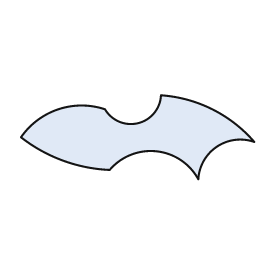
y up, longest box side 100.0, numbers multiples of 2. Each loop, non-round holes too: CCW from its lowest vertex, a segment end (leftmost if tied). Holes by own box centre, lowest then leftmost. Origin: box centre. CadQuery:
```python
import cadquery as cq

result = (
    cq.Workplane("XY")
    .moveTo(26.0, -18.0)
    .threePointArc((34.0, -4.0), (50.0, -2.0))
    .threePointArc((32.0, 12.0), (10.0, 18.0))
    .threePointArc((0.0, 6.0), (-14.0, 12.0))
    .threePointArc((-34.0, 12.0), (-50.0, 0.0))
    .threePointArc((-32.0, -10.0), (-12.0, -14.0))
    .threePointArc((8.0, -6.0), (26.0, -18.0))
    .close()
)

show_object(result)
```